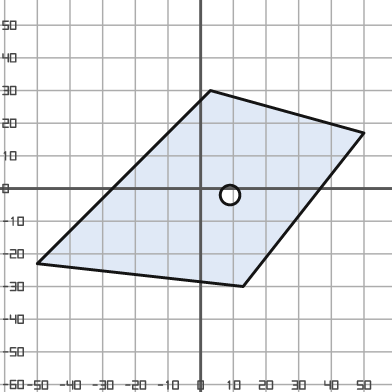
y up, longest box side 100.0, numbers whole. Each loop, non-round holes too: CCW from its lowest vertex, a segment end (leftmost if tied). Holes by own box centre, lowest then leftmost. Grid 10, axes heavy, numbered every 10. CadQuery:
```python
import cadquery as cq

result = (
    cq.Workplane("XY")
    .moveTo(13.0, -30.0)
    .lineTo(50.0, 17.0)
    .lineTo(3.0, 30.0)
    .lineTo(-50.0, -23.0)
    .close()
    .moveTo(9.0, -2.0)
    .circle(3.0)
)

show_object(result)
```